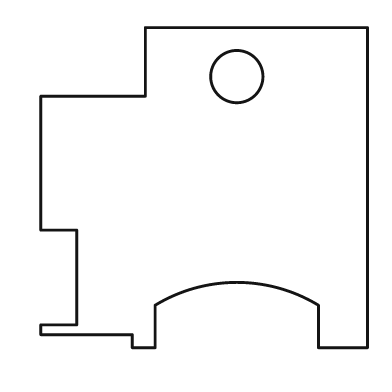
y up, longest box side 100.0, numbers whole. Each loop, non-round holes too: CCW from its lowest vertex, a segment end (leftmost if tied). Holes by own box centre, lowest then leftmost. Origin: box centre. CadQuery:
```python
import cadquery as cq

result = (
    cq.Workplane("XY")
    .moveTo(-22.0, -49.0)
    .lineTo(-15.0, -49.0)
    .lineTo(-15.0, -36.0)
    .threePointArc((10.0, -29.0), (35.0, -36.0))
    .lineTo(35.0, -49.0)
    .lineTo(50.0, -49.0)
    .lineTo(50.0, 49.0)
    .lineTo(-18.0, 49.0)
    .lineTo(-18.0, 28.0)
    .lineTo(-50.0, 28.0)
    .lineTo(-50.0, -13.0)
    .lineTo(-39.0, -13.0)
    .lineTo(-39.0, -42.0)
    .lineTo(-50.0, -42.0)
    .lineTo(-50.0, -45.0)
    .lineTo(-22.0, -45.0)
    .close()
    .moveTo(10.0, 34.0)
    .circle(8.0)
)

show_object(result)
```